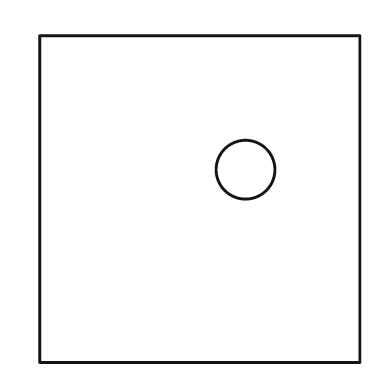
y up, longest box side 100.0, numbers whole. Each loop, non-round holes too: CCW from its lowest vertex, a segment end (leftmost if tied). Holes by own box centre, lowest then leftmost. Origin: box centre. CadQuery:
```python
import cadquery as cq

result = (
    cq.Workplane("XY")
    .moveTo(-49.0, -50.0)
    .lineTo(49.0, -50.0)
    .lineTo(49.0, 50.0)
    .lineTo(-49.0, 50.0)
    .close()
    .moveTo(14.0, 9.0)
    .circle(9.0)
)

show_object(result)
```